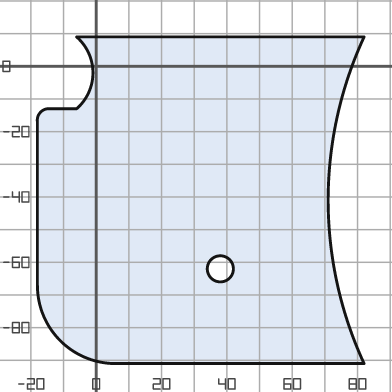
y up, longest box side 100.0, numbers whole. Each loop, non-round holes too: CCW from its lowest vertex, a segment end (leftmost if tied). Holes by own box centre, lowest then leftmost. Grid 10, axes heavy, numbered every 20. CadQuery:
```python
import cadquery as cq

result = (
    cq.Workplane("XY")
    .moveTo(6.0, -91.0)
    .lineTo(82.0, -91.0)
    .threePointArc((71.0, -41.0), (82.0, 9.0))
    .lineTo(-6.0, 9.0)
    .threePointArc((-1.0, -2.0), (-6.0, -13.0))
    .lineTo(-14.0, -13.0)
    .threePointArc((-17.0, -14.0), (-18.0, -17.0))
    .lineTo(-18.0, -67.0)
    .threePointArc((-11.0, -84.0), (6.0, -91.0))
    .close()
    .moveTo(38.0, -62.0)
    .circle(4.0)
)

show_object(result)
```